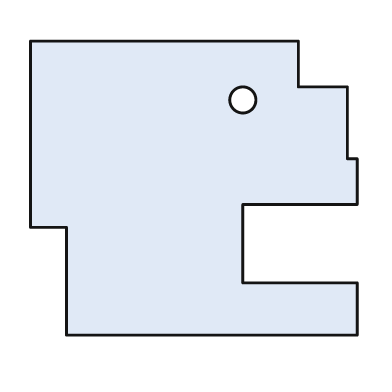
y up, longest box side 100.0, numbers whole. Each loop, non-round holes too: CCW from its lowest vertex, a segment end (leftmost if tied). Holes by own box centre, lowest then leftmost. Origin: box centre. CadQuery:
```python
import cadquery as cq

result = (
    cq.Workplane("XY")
    .moveTo(-39.0, -45.0)
    .lineTo(50.0, -45.0)
    .lineTo(50.0, -29.0)
    .lineTo(15.0, -29.0)
    .lineTo(15.0, -5.0)
    .lineTo(50.0, -5.0)
    .lineTo(50.0, 9.0)
    .lineTo(47.0, 9.0)
    .lineTo(47.0, 31.0)
    .lineTo(32.0, 31.0)
    .lineTo(32.0, 45.0)
    .lineTo(-50.0, 45.0)
    .lineTo(-50.0, -12.0)
    .lineTo(-39.0, -12.0)
    .close()
    .moveTo(15.0, 27.0)
    .circle(4.0)
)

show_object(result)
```